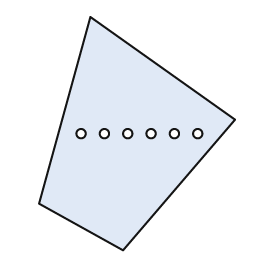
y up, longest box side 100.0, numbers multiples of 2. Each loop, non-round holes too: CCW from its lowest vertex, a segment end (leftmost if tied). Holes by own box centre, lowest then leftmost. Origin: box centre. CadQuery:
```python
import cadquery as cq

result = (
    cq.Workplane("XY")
    .moveTo(-6.0, -50.0)
    .lineTo(42.0, 6.0)
    .lineTo(-20.0, 50.0)
    .lineTo(-42.0, -30.0)
    .close()
    .moveTo(-24.0, 0.0)
    .circle(2.0)
    .moveTo(-14.0, 0.0)
    .circle(2.0)
    .moveTo(-4.0, 0.0)
    .circle(2.0)
    .moveTo(6.0, 0.0)
    .circle(2.0)
    .moveTo(16.0, 0.0)
    .circle(2.0)
    .moveTo(26.0, 0.0)
    .circle(2.0)
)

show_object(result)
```